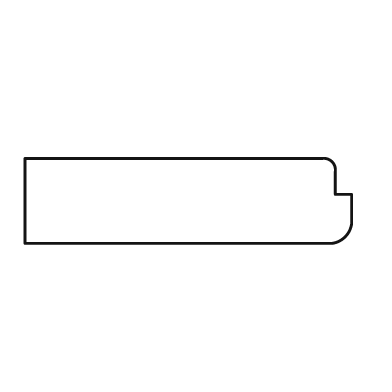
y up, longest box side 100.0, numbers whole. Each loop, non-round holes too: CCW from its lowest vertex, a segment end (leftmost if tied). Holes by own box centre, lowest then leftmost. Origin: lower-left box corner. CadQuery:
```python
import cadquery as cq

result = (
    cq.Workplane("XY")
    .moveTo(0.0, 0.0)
    .lineTo(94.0, 0.0)
    .threePointArc((98.0, 2.0), (100.0, 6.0))
    .lineTo(100.0, 15.0)
    .lineTo(95.0, 15.0)
    .lineTo(95.0, 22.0)
    .threePointArc((94.0, 25.0), (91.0, 26.0))
    .lineTo(0.0, 26.0)
    .close()
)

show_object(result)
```